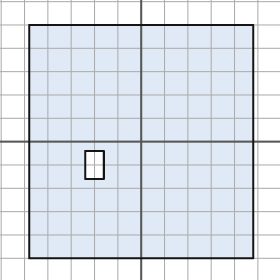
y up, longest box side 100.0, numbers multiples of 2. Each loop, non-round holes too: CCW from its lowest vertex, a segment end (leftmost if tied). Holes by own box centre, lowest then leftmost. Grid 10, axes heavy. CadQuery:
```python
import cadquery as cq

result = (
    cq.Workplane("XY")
    .moveTo(-48.0, -50.0)
    .lineTo(48.0, -50.0)
    .lineTo(48.0, 50.0)
    .lineTo(-48.0, 50.0)
    .close()
    .moveTo(-24.0, -16.0)
    .lineTo(-16.0, -16.0)
    .lineTo(-16.0, -4.0)
    .lineTo(-24.0, -4.0)
    .close()
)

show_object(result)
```